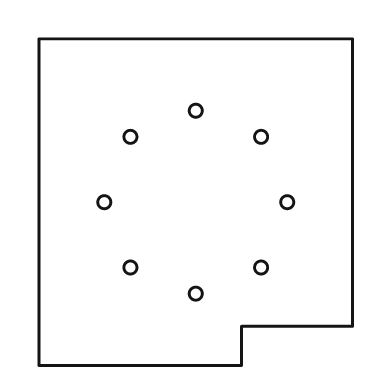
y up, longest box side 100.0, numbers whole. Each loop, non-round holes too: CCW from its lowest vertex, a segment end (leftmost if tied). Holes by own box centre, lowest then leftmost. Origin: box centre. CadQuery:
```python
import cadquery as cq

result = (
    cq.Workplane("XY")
    .moveTo(-48.0, -50.0)
    .lineTo(14.0, -50.0)
    .lineTo(14.0, -38.0)
    .lineTo(48.0, -38.0)
    .lineTo(48.0, 50.0)
    .lineTo(-48.0, 50.0)
    .close()
    .moveTo(0.0, -28.0)
    .circle(2.0)
    .moveTo(-20.0, -20.0)
    .circle(2.0)
    .moveTo(20.0, -20.0)
    .circle(2.0)
    .moveTo(-28.0, 0.0)
    .circle(2.0)
    .moveTo(28.0, 0.0)
    .circle(2.0)
    .moveTo(-20.0, 20.0)
    .circle(2.0)
    .moveTo(20.0, 20.0)
    .circle(2.0)
    .moveTo(0.0, 28.0)
    .circle(2.0)
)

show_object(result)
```